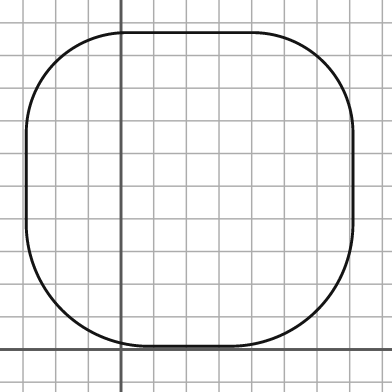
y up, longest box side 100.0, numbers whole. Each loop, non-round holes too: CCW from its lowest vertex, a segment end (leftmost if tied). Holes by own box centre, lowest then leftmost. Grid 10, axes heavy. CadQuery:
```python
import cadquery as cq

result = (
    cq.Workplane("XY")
    .moveTo(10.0, 1.0)
    .lineTo(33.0, 1.0)
    .threePointArc((60.0, 12.0), (71.0, 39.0))
    .lineTo(71.0, 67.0)
    .threePointArc((62.0, 88.0), (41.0, 97.0))
    .lineTo(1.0, 97.0)
    .threePointArc((-20.0, 88.0), (-29.0, 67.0))
    .lineTo(-29.0, 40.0)
    .threePointArc((-18.0, 12.0), (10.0, 1.0))
    .close()
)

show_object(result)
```